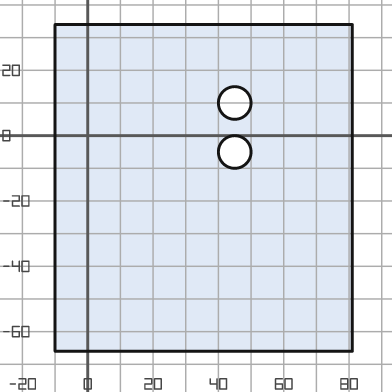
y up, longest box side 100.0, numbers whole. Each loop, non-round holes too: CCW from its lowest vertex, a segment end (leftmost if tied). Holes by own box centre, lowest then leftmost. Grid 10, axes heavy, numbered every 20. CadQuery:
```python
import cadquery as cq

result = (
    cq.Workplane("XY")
    .moveTo(-10.0, -66.0)
    .lineTo(81.0, -66.0)
    .lineTo(81.0, 34.0)
    .lineTo(-10.0, 34.0)
    .close()
    .moveTo(45.0, -5.0)
    .circle(5.0)
    .moveTo(45.0, 10.0)
    .circle(5.0)
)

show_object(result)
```